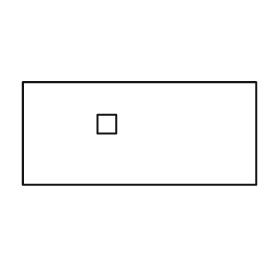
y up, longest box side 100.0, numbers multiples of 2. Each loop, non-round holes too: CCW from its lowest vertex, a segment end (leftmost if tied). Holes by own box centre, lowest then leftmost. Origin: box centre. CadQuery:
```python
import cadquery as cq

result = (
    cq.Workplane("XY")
    .moveTo(-50.0, -22.0)
    .lineTo(50.0, -22.0)
    .lineTo(50.0, 22.0)
    .lineTo(-50.0, 22.0)
    .close()
    .moveTo(-18.0, 0.0)
    .lineTo(-10.0, 0.0)
    .lineTo(-10.0, 8.0)
    .lineTo(-18.0, 8.0)
    .close()
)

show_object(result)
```